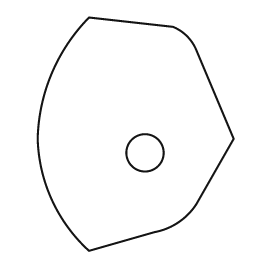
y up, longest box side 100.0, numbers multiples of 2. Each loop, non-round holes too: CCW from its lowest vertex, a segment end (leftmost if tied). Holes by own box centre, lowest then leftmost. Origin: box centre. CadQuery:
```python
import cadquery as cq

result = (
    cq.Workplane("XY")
    .moveTo(-20.0, -50.0)
    .lineTo(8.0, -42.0)
    .threePointArc((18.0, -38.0), (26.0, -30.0))
    .lineTo(42.0, -2.0)
    .lineTo(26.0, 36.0)
    .threePointArc((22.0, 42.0), (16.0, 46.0))
    .lineTo(-20.0, 50.0)
    .threePointArc((-36.0, 26.0), (-42.0, -2.0))
    .threePointArc((-36.0, -28.0), (-20.0, -50.0))
    .close()
    .moveTo(4.0, -8.0)
    .circle(8.0)
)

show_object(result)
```